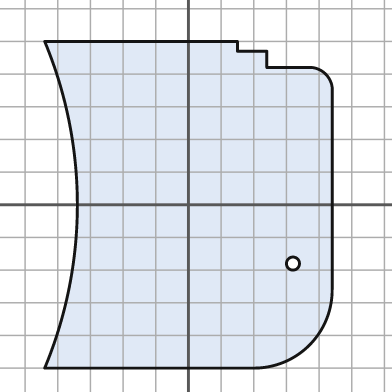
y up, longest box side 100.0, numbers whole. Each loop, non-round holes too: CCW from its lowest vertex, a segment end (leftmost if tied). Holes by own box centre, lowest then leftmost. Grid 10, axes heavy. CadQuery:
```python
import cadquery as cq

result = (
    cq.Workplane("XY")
    .moveTo(-44.0, -50.0)
    .lineTo(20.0, -50.0)
    .threePointArc((37.0, -43.0), (44.0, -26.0))
    .lineTo(44.0, 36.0)
    .threePointArc((42.0, 40.0), (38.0, 42.0))
    .lineTo(24.0, 42.0)
    .lineTo(24.0, 47.0)
    .lineTo(15.0, 47.0)
    .lineTo(15.0, 50.0)
    .lineTo(-44.0, 50.0)
    .threePointArc((-34.0, 0.0), (-44.0, -50.0))
    .close()
    .moveTo(32.0, -18.0)
    .circle(2.0)
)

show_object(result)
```